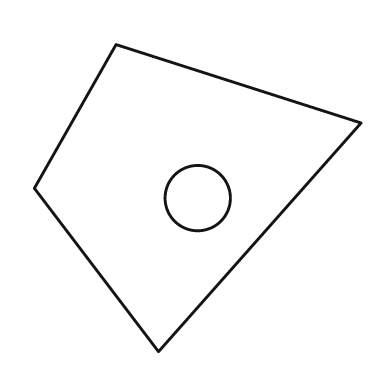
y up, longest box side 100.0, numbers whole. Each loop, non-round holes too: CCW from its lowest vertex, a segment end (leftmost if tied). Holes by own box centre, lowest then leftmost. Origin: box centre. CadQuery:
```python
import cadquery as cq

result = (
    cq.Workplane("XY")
    .moveTo(-12.0, -47.0)
    .lineTo(50.0, 23.0)
    .lineTo(-25.0, 47.0)
    .lineTo(-50.0, 3.0)
    .close()
    .moveTo(0.0, 0.0)
    .circle(10.0)
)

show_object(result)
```